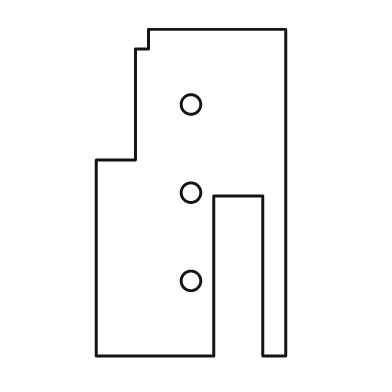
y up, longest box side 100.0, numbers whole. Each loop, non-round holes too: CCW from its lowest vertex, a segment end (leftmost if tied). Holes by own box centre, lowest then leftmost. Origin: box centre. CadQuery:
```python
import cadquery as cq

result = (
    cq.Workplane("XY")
    .moveTo(-29.0, -50.0)
    .lineTo(7.0, -50.0)
    .lineTo(7.0, -1.0)
    .lineTo(22.0, -1.0)
    .lineTo(22.0, -50.0)
    .lineTo(29.0, -50.0)
    .lineTo(29.0, 50.0)
    .lineTo(-13.0, 50.0)
    .lineTo(-13.0, 44.0)
    .lineTo(-17.0, 44.0)
    .lineTo(-17.0, 10.0)
    .lineTo(-29.0, 10.0)
    .close()
    .moveTo(0.0, -27.0)
    .circle(3.0)
    .moveTo(0.0, 0.0)
    .circle(3.0)
    .moveTo(0.0, 27.0)
    .circle(3.0)
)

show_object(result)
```